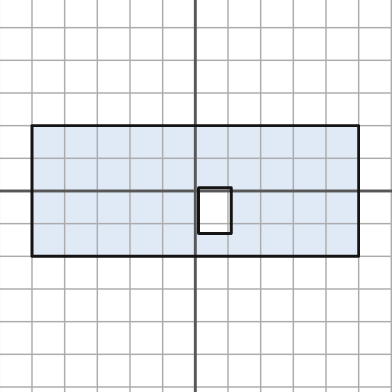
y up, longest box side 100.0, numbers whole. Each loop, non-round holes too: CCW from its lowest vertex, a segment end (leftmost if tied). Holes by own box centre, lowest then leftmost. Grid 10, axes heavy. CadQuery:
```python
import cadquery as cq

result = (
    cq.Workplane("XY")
    .moveTo(-50.0, -20.0)
    .lineTo(50.0, -20.0)
    .lineTo(50.0, 20.0)
    .lineTo(-50.0, 20.0)
    .close()
    .moveTo(1.0, -13.0)
    .lineTo(11.0, -13.0)
    .lineTo(11.0, 1.0)
    .lineTo(1.0, 1.0)
    .close()
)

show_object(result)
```